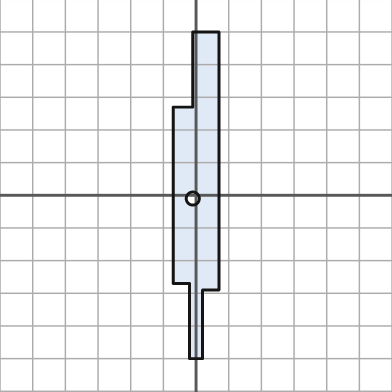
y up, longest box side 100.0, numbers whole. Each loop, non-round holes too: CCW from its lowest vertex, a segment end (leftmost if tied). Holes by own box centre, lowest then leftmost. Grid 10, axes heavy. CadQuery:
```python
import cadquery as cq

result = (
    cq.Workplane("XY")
    .moveTo(-2.0, -50.0)
    .lineTo(2.0, -50.0)
    .lineTo(2.0, -29.0)
    .lineTo(7.0, -29.0)
    .lineTo(7.0, 50.0)
    .lineTo(-1.0, 50.0)
    .lineTo(-1.0, 27.0)
    .lineTo(-7.0, 27.0)
    .lineTo(-7.0, -27.0)
    .lineTo(-2.0, -27.0)
    .close()
    .moveTo(-1.0, -1.0)
    .circle(2.0)
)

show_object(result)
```